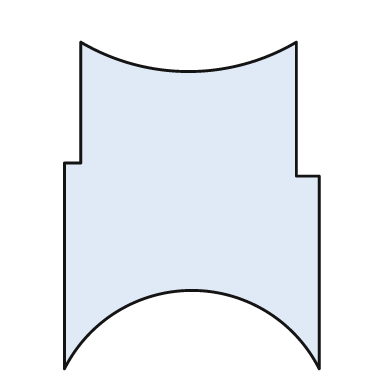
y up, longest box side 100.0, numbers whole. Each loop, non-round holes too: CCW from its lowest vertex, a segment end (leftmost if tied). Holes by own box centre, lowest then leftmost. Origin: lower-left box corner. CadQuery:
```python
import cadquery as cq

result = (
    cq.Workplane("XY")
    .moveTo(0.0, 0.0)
    .threePointArc((39.0, 24.0), (78.0, 0.0))
    .lineTo(78.0, 59.0)
    .lineTo(71.0, 59.0)
    .lineTo(71.0, 100.0)
    .threePointArc((38.0, 91.0), (5.0, 100.0))
    .lineTo(5.0, 63.0)
    .lineTo(0.0, 63.0)
    .close()
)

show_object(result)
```